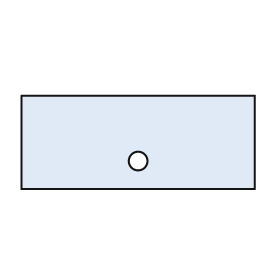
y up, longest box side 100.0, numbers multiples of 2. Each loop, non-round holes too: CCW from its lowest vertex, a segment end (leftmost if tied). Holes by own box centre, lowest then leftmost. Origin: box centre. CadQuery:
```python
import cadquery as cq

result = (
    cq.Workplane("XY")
    .moveTo(-50.0, -20.0)
    .lineTo(50.0, -20.0)
    .lineTo(50.0, 20.0)
    .lineTo(-50.0, 20.0)
    .close()
    .moveTo(0.0, -8.0)
    .circle(4.0)
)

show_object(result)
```